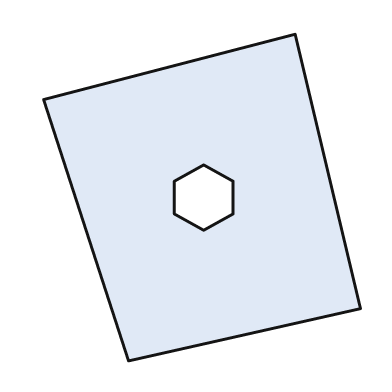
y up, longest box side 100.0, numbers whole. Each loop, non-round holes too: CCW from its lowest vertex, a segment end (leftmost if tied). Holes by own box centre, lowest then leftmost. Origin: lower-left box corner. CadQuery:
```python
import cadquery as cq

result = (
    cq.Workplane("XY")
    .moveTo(26.0, 0.0)
    .lineTo(97.0, 16.0)
    .lineTo(77.0, 100.0)
    .lineTo(0.0, 80.0)
    .close()
    .moveTo(49.0, 40.0)
    .lineTo(58.0, 45.0)
    .lineTo(58.0, 55.0)
    .lineTo(49.0, 60.0)
    .lineTo(40.0, 55.0)
    .lineTo(40.0, 45.0)
    .close()
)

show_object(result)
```